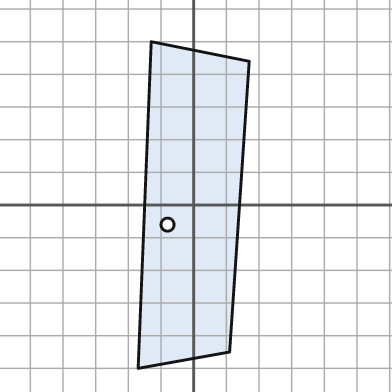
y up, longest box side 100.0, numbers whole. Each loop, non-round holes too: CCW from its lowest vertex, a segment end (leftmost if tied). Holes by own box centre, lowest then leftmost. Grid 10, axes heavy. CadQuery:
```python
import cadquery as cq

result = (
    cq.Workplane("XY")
    .moveTo(-17.0, -50.0)
    .lineTo(11.0, -45.0)
    .lineTo(17.0, 44.0)
    .lineTo(-13.0, 50.0)
    .close()
    .moveTo(-8.0, -6.0)
    .circle(2.0)
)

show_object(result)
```